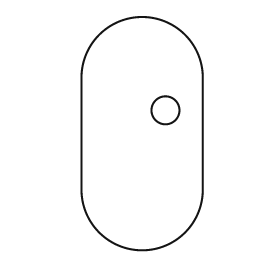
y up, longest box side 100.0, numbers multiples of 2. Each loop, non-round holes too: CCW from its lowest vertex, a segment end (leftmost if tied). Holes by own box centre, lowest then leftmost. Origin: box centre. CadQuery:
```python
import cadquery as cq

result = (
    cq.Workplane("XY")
    .moveTo(-26.0, -24.0)
    .threePointArc((0.0, -50.0), (26.0, -24.0))
    .lineTo(26.0, 24.0)
    .threePointArc((0.0, 50.0), (-26.0, 24.0))
    .close()
    .moveTo(10.0, 10.0)
    .circle(6.0)
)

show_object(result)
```